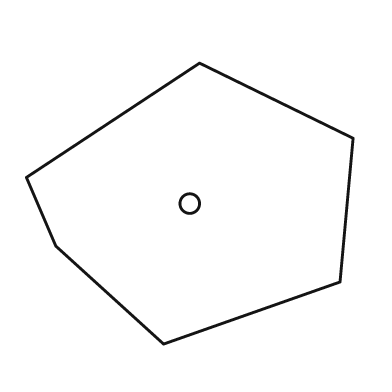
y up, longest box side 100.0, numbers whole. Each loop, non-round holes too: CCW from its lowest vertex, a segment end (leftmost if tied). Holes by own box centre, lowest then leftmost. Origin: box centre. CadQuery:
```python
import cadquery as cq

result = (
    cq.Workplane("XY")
    .moveTo(-8.0, -43.0)
    .lineTo(46.0, -24.0)
    .lineTo(50.0, 20.0)
    .lineTo(3.0, 43.0)
    .lineTo(-50.0, 8.0)
    .lineTo(-41.0, -13.0)
    .close()
    .moveTo(0.0, 0.0)
    .circle(3.0)
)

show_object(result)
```